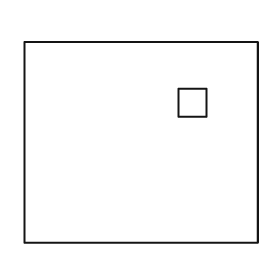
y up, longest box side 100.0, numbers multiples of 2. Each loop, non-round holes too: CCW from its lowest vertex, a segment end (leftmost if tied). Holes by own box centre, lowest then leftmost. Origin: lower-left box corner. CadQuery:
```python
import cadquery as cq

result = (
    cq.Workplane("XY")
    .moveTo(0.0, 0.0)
    .lineTo(100.0, 0.0)
    .lineTo(100.0, 86.0)
    .lineTo(0.0, 86.0)
    .close()
    .moveTo(66.0, 54.0)
    .lineTo(78.0, 54.0)
    .lineTo(78.0, 66.0)
    .lineTo(66.0, 66.0)
    .close()
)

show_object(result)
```